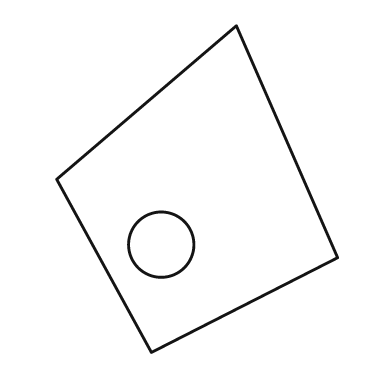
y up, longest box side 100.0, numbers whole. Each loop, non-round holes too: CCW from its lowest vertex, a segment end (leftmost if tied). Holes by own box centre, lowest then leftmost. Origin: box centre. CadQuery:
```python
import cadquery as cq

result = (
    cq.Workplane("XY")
    .moveTo(-14.0, -50.0)
    .lineTo(43.0, -21.0)
    .lineTo(12.0, 50.0)
    .lineTo(-43.0, 3.0)
    .close()
    .moveTo(-11.0, -17.0)
    .circle(10.0)
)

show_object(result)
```